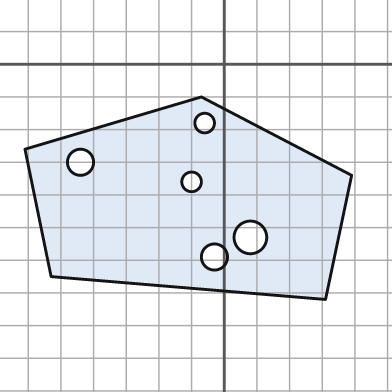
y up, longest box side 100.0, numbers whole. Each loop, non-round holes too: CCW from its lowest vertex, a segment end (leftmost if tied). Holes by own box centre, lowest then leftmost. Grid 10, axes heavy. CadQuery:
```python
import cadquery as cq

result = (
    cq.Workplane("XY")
    .moveTo(31.0, -72.0)
    .lineTo(39.0, -34.0)
    .lineTo(-7.0, -10.0)
    .lineTo(-61.0, -26.0)
    .lineTo(-53.0, -65.0)
    .close()
    .moveTo(-3.0, -59.0)
    .circle(4.0)
    .moveTo(8.0, -53.0)
    .circle(5.0)
    .moveTo(-10.0, -36.0)
    .circle(3.0)
    .moveTo(-44.0, -30.0)
    .circle(4.0)
    .moveTo(-6.0, -18.0)
    .circle(3.0)
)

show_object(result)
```